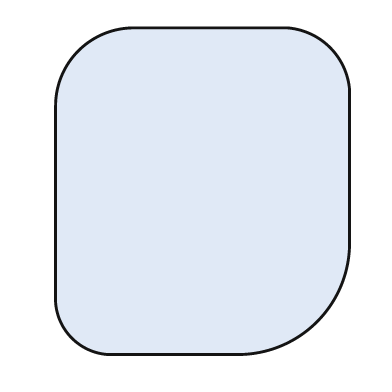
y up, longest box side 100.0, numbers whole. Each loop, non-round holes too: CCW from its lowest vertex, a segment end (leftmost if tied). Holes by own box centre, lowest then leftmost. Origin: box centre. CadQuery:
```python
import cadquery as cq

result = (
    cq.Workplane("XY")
    .moveTo(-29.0, -50.0)
    .lineTo(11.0, -50.0)
    .threePointArc((35.0, -40.0), (45.0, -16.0))
    .lineTo(45.0, 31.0)
    .threePointArc((39.0, 44.0), (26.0, 50.0))
    .lineTo(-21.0, 50.0)
    .threePointArc((-38.0, 43.0), (-45.0, 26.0))
    .lineTo(-45.0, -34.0)
    .threePointArc((-40.0, -45.0), (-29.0, -50.0))
    .close()
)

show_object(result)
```